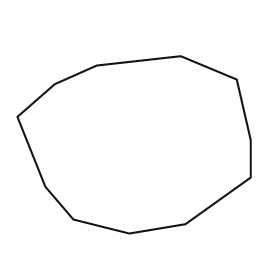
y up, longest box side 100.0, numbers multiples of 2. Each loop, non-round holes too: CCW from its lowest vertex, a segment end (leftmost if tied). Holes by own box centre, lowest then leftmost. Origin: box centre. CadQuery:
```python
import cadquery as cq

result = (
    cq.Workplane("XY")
    .moveTo(-2.0, -38.0)
    .lineTo(22.0, -34.0)
    .lineTo(50.0, -14.0)
    .lineTo(50.0, 2.0)
    .lineTo(44.0, 28.0)
    .lineTo(20.0, 38.0)
    .lineTo(-16.0, 34.0)
    .lineTo(-34.0, 26.0)
    .lineTo(-50.0, 12.0)
    .lineTo(-38.0, -18.0)
    .lineTo(-26.0, -32.0)
    .close()
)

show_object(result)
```